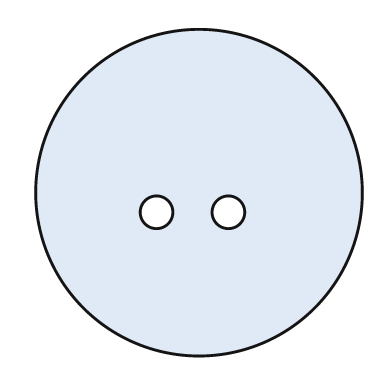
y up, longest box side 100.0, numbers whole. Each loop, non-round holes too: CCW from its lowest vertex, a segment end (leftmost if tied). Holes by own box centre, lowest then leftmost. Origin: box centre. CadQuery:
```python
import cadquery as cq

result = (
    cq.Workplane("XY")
    .moveTo(0.0, 0.0)
    .circle(50.0)
    .moveTo(-13.0, -6.0)
    .circle(5.0)
    .moveTo(9.0, -6.0)
    .circle(5.0)
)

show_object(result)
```